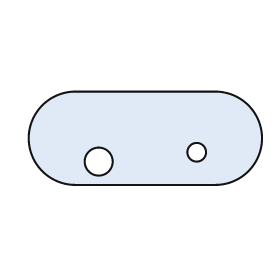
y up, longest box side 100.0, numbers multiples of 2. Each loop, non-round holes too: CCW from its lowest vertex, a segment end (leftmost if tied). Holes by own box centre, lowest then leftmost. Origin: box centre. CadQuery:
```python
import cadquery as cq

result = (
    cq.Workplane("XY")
    .moveTo(-30.0, -20.0)
    .lineTo(30.0, -20.0)
    .threePointArc((50.0, 0.0), (30.0, 20.0))
    .lineTo(-30.0, 20.0)
    .threePointArc((-50.0, 0.0), (-30.0, -20.0))
    .close()
    .moveTo(-20.0, -10.0)
    .circle(6.0)
    .moveTo(22.0, -6.0)
    .circle(4.0)
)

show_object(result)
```